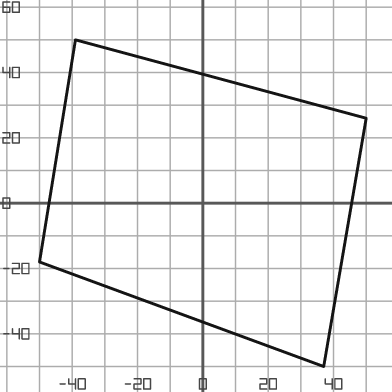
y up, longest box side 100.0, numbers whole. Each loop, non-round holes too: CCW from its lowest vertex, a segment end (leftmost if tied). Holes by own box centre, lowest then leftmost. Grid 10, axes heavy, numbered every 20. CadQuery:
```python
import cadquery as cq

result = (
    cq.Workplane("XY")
    .moveTo(37.0, -50.0)
    .lineTo(50.0, 26.0)
    .lineTo(-39.0, 50.0)
    .lineTo(-50.0, -18.0)
    .close()
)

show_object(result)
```